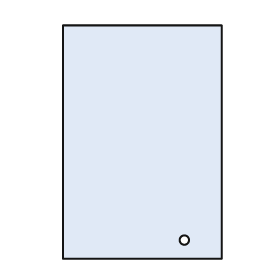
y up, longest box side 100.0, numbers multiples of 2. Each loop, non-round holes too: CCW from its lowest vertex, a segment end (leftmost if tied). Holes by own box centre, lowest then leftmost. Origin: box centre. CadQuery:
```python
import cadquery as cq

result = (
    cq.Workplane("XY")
    .moveTo(-34.0, -50.0)
    .lineTo(34.0, -50.0)
    .lineTo(34.0, 50.0)
    .lineTo(-34.0, 50.0)
    .close()
    .moveTo(18.0, -42.0)
    .circle(2.0)
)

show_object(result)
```